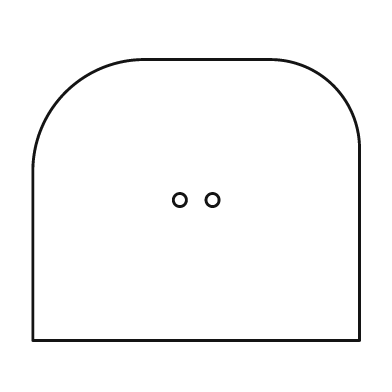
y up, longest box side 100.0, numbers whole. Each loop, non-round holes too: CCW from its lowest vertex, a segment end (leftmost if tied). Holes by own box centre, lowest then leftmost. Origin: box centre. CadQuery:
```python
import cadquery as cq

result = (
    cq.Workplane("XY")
    .moveTo(-50.0, -43.0)
    .lineTo(50.0, -43.0)
    .lineTo(50.0, 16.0)
    .threePointArc((42.0, 35.0), (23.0, 43.0))
    .lineTo(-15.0, 43.0)
    .threePointArc((-40.0, 33.0), (-50.0, 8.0))
    .close()
    .moveTo(-5.0, 0.0)
    .circle(2.0)
    .moveTo(5.0, 0.0)
    .circle(2.0)
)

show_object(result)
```